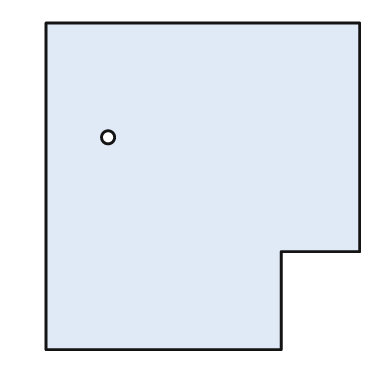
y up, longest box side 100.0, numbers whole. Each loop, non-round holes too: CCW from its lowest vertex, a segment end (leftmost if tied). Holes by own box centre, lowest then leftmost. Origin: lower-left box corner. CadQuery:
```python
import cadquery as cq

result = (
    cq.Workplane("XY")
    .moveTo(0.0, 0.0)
    .lineTo(72.0, 0.0)
    .lineTo(72.0, 30.0)
    .lineTo(96.0, 30.0)
    .lineTo(96.0, 100.0)
    .lineTo(0.0, 100.0)
    .close()
    .moveTo(19.0, 65.0)
    .circle(2.0)
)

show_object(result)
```